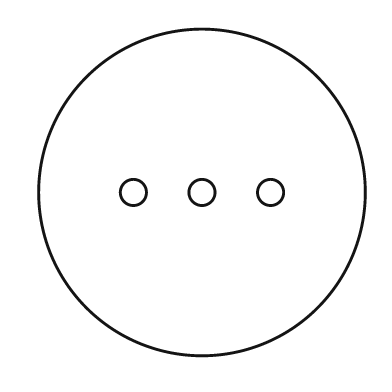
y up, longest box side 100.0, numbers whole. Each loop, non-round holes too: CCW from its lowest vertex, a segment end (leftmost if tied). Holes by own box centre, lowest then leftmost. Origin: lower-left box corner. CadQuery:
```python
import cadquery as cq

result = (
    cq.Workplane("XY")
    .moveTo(50.0, 50.0)
    .circle(50.0)
    .moveTo(29.0, 50.0)
    .circle(4.0)
    .moveTo(50.0, 50.0)
    .circle(4.0)
    .moveTo(71.0, 50.0)
    .circle(4.0)
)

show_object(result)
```